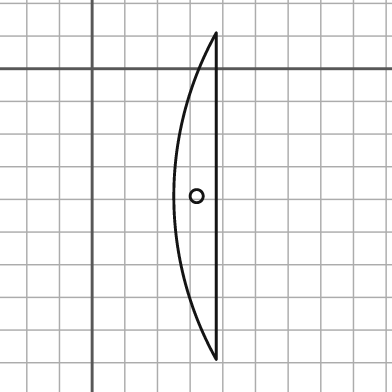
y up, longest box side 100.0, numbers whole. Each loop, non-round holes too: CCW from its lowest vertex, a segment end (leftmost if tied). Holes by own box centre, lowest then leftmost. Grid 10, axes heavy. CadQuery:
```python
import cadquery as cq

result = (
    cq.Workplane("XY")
    .moveTo(38.0, -89.0)
    .lineTo(38.0, 11.0)
    .threePointArc((25.0, -39.0), (38.0, -89.0))
    .close()
    .moveTo(32.0, -39.0)
    .circle(2.0)
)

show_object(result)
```